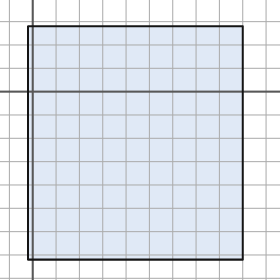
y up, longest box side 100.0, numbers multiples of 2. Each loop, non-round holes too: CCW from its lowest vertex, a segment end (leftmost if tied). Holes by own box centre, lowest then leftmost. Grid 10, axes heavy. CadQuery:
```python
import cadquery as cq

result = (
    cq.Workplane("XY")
    .moveTo(-2.0, -72.0)
    .lineTo(90.0, -72.0)
    .lineTo(90.0, 28.0)
    .lineTo(-2.0, 28.0)
    .close()
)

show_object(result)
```